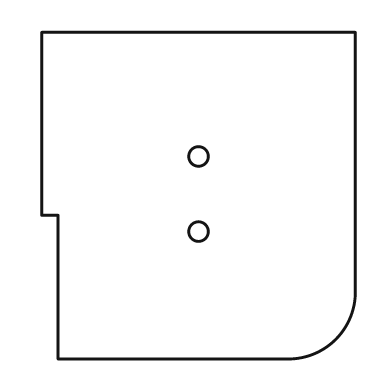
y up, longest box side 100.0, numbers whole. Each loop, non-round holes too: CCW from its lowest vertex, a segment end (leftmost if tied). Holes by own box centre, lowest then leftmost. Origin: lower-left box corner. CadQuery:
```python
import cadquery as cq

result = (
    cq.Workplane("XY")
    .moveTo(5.0, 0.0)
    .lineTo(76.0, 0.0)
    .threePointArc((90.0, 6.0), (96.0, 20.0))
    .lineTo(96.0, 100.0)
    .lineTo(0.0, 100.0)
    .lineTo(0.0, 44.0)
    .lineTo(5.0, 44.0)
    .close()
    .moveTo(48.0, 39.0)
    .circle(3.0)
    .moveTo(48.0, 62.0)
    .circle(3.0)
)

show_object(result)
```